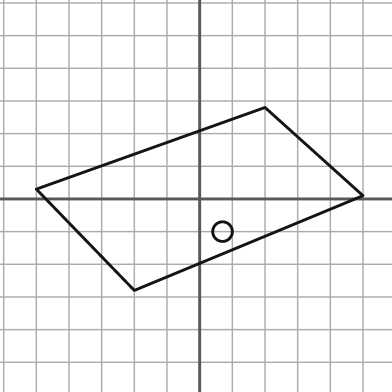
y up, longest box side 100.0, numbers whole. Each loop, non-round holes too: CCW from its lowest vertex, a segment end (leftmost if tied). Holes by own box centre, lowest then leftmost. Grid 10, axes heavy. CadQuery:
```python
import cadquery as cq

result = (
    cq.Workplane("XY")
    .moveTo(-20.0, -28.0)
    .lineTo(50.0, 1.0)
    .lineTo(20.0, 28.0)
    .lineTo(-50.0, 3.0)
    .close()
    .moveTo(7.0, -10.0)
    .circle(3.0)
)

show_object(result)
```